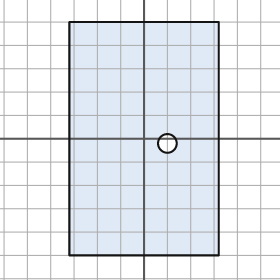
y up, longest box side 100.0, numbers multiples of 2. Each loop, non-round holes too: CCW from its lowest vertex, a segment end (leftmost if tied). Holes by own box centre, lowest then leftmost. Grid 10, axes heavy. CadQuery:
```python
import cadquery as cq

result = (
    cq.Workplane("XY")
    .moveTo(-32.0, -50.0)
    .lineTo(32.0, -50.0)
    .lineTo(32.0, 50.0)
    .lineTo(-32.0, 50.0)
    .close()
    .moveTo(10.0, -2.0)
    .circle(4.0)
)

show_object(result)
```